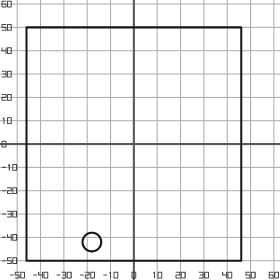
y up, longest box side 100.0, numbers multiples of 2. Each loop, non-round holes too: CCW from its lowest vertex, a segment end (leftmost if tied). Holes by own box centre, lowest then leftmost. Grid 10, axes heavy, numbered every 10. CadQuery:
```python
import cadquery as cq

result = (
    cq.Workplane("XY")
    .moveTo(-46.0, -50.0)
    .lineTo(46.0, -50.0)
    .lineTo(46.0, 50.0)
    .lineTo(-46.0, 50.0)
    .close()
    .moveTo(-18.0, -42.0)
    .circle(4.0)
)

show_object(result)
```